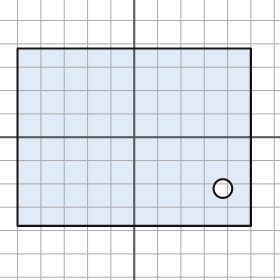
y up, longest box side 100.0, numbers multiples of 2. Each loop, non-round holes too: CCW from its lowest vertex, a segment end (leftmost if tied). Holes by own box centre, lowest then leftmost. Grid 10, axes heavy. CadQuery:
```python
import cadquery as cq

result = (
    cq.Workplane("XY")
    .moveTo(-50.0, -38.0)
    .lineTo(50.0, -38.0)
    .lineTo(50.0, 38.0)
    .lineTo(-50.0, 38.0)
    .close()
    .moveTo(38.0, -22.0)
    .circle(4.0)
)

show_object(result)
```